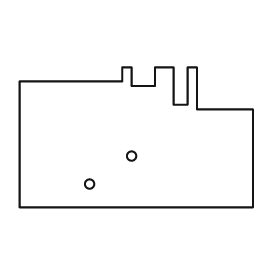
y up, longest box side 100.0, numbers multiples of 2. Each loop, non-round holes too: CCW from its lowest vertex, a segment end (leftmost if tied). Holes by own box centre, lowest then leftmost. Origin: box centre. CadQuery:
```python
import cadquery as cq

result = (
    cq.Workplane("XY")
    .moveTo(-50.0, -30.0)
    .lineTo(50.0, -30.0)
    .lineTo(50.0, 12.0)
    .lineTo(26.0, 12.0)
    .lineTo(26.0, 30.0)
    .lineTo(22.0, 30.0)
    .lineTo(22.0, 14.0)
    .lineTo(16.0, 14.0)
    .lineTo(16.0, 30.0)
    .lineTo(8.0, 30.0)
    .lineTo(8.0, 22.0)
    .lineTo(-2.0, 22.0)
    .lineTo(-2.0, 30.0)
    .lineTo(-6.0, 30.0)
    .lineTo(-6.0, 24.0)
    .lineTo(-50.0, 24.0)
    .close()
    .moveTo(-20.0, -20.0)
    .circle(2.0)
    .moveTo(-2.0, -8.0)
    .circle(2.0)
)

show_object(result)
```